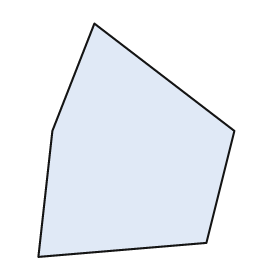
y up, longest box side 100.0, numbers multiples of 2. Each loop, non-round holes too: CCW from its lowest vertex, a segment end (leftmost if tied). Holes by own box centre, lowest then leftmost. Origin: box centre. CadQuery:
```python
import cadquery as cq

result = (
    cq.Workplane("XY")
    .moveTo(-42.0, -50.0)
    .lineTo(30.0, -44.0)
    .lineTo(42.0, 4.0)
    .lineTo(-18.0, 50.0)
    .lineTo(-36.0, 4.0)
    .close()
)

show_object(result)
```